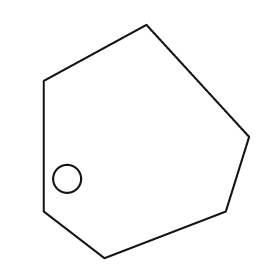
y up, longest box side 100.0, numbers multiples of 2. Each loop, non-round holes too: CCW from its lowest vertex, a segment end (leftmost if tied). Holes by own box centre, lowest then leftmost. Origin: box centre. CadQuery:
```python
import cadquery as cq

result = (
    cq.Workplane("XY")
    .moveTo(-18.0, -50.0)
    .lineTo(34.0, -30.0)
    .lineTo(44.0, 2.0)
    .lineTo(0.0, 50.0)
    .lineTo(-44.0, 26.0)
    .lineTo(-44.0, -30.0)
    .close()
    .moveTo(-34.0, -16.0)
    .circle(6.0)
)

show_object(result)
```